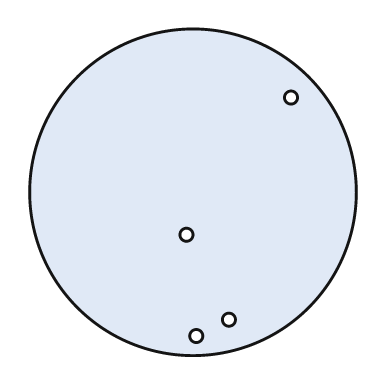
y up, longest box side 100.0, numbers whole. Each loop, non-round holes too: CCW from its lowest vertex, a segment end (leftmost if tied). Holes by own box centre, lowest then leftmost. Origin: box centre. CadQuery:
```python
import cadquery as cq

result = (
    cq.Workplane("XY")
    .moveTo(0.0, 0.0)
    .circle(50.0)
    .moveTo(1.0, -44.0)
    .circle(2.0)
    .moveTo(11.0, -39.0)
    .circle(2.0)
    .moveTo(-2.0, -13.0)
    .circle(2.0)
    .moveTo(30.0, 29.0)
    .circle(2.0)
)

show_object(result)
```